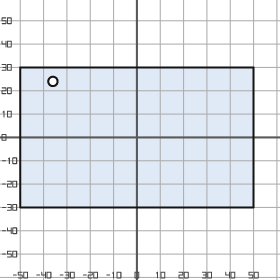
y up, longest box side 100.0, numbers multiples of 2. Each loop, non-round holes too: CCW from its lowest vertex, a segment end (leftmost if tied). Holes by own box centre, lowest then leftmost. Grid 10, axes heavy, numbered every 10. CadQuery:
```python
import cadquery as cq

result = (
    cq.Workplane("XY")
    .moveTo(-50.0, -30.0)
    .lineTo(50.0, -30.0)
    .lineTo(50.0, 30.0)
    .lineTo(-50.0, 30.0)
    .close()
    .moveTo(-36.0, 24.0)
    .circle(2.0)
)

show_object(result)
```